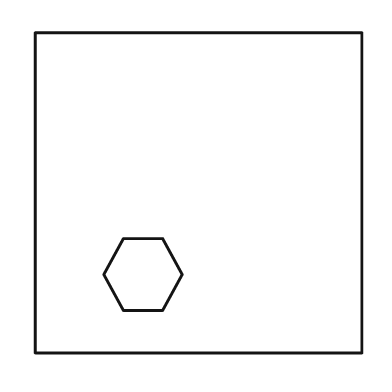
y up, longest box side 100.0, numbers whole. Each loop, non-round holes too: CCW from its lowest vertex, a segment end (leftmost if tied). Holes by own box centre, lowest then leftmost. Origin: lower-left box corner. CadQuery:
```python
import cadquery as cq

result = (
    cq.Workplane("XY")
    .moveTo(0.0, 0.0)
    .lineTo(100.0, 0.0)
    .lineTo(100.0, 98.0)
    .lineTo(0.0, 98.0)
    .close()
    .moveTo(27.0, 13.0)
    .lineTo(39.0, 13.0)
    .lineTo(45.0, 24.0)
    .lineTo(39.0, 35.0)
    .lineTo(27.0, 35.0)
    .lineTo(21.0, 24.0)
    .close()
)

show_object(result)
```